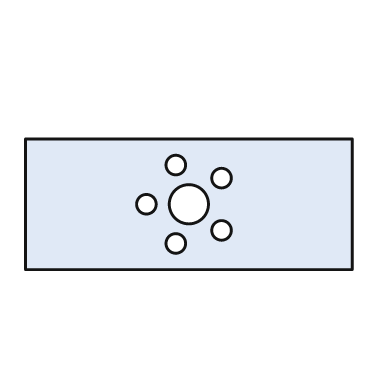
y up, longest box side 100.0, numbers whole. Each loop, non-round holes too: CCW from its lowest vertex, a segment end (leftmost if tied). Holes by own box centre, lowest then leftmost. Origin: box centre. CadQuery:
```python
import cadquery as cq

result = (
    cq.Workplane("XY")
    .moveTo(-50.0, -20.0)
    .lineTo(50.0, -20.0)
    .lineTo(50.0, 20.0)
    .lineTo(-50.0, 20.0)
    .close()
    .moveTo(-4.0, -12.0)
    .circle(3.0)
    .moveTo(10.0, -8.0)
    .circle(3.0)
    .moveTo(-13.0, 0.0)
    .circle(3.0)
    .moveTo(0.0, 0.0)
    .circle(6.0)
    .moveTo(10.0, 8.0)
    .circle(3.0)
    .moveTo(-4.0, 12.0)
    .circle(3.0)
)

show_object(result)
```